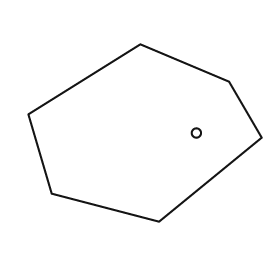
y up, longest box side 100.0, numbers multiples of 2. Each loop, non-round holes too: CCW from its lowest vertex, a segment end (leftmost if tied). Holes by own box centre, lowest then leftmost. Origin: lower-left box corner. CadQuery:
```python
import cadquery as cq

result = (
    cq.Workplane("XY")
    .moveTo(56.0, 0.0)
    .lineTo(100.0, 36.0)
    .lineTo(86.0, 60.0)
    .lineTo(48.0, 76.0)
    .lineTo(0.0, 46.0)
    .lineTo(10.0, 12.0)
    .close()
    .moveTo(72.0, 38.0)
    .circle(2.0)
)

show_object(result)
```